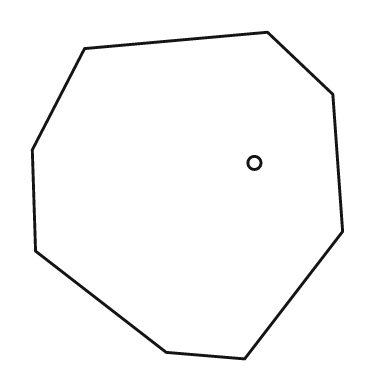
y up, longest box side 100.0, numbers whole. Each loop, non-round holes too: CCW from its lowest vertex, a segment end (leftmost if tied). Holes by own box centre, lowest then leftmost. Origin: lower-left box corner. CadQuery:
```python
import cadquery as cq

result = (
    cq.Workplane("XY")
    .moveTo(65.0, 0.0)
    .lineTo(95.0, 39.0)
    .lineTo(92.0, 81.0)
    .lineTo(72.0, 100.0)
    .lineTo(16.0, 95.0)
    .lineTo(0.0, 64.0)
    .lineTo(1.0, 33.0)
    .lineTo(41.0, 2.0)
    .close()
    .moveTo(68.0, 60.0)
    .circle(2.0)
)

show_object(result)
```